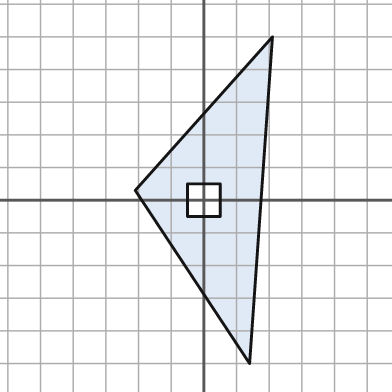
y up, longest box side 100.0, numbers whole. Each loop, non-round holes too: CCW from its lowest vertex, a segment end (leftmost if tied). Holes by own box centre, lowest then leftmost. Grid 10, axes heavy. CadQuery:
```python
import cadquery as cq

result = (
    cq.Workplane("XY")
    .moveTo(14.0, -50.0)
    .lineTo(21.0, 50.0)
    .lineTo(-21.0, 3.0)
    .close()
    .moveTo(-5.0, -5.0)
    .lineTo(5.0, -5.0)
    .lineTo(5.0, 5.0)
    .lineTo(-5.0, 5.0)
    .close()
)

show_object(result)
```